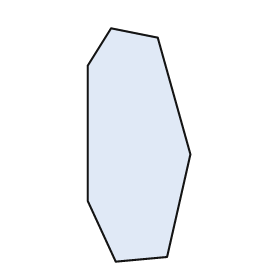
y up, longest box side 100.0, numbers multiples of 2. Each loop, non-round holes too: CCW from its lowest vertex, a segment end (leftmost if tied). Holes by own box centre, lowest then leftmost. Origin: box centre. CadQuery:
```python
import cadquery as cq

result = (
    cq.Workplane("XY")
    .moveTo(-10.0, -50.0)
    .lineTo(12.0, -48.0)
    .lineTo(22.0, -4.0)
    .lineTo(8.0, 46.0)
    .lineTo(-12.0, 50.0)
    .lineTo(-22.0, 34.0)
    .lineTo(-22.0, -24.0)
    .close()
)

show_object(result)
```